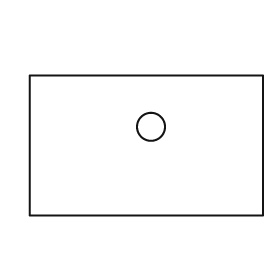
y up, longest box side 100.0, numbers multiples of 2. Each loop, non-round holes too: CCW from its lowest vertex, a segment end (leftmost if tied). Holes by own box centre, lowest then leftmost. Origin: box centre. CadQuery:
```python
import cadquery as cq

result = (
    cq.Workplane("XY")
    .moveTo(-50.0, -30.0)
    .lineTo(50.0, -30.0)
    .lineTo(50.0, 30.0)
    .lineTo(-50.0, 30.0)
    .close()
    .moveTo(2.0, 8.0)
    .circle(6.0)
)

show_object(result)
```